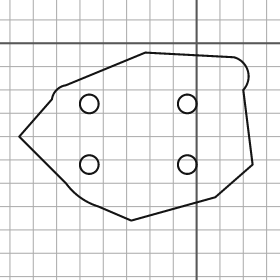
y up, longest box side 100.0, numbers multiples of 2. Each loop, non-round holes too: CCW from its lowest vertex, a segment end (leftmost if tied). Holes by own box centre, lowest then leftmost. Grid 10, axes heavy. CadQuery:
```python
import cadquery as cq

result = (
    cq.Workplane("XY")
    .moveTo(-28.0, -76.0)
    .lineTo(8.0, -66.0)
    .lineTo(24.0, -52.0)
    .lineTo(20.0, -20.0)
    .threePointArc((22.0, -12.0), (16.0, -6.0))
    .lineTo(-22.0, -4.0)
    .lineTo(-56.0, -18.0)
    .threePointArc((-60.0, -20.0), (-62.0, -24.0))
    .lineTo(-76.0, -40.0)
    .lineTo(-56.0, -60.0)
    .threePointArc((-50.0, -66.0), (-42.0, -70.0))
    .close()
    .moveTo(-46.0, -52.0)
    .circle(4.0)
    .moveTo(-4.0, -52.0)
    .circle(4.0)
    .moveTo(-46.0, -26.0)
    .circle(4.0)
    .moveTo(-4.0, -26.0)
    .circle(4.0)
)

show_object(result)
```